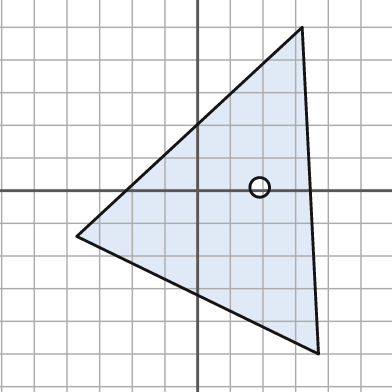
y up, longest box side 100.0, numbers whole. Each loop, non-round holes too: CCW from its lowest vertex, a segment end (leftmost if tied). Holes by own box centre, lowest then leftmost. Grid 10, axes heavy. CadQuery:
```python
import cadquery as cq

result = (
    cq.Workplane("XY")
    .moveTo(37.0, -50.0)
    .lineTo(32.0, 50.0)
    .lineTo(-37.0, -14.0)
    .close()
    .moveTo(19.0, 1.0)
    .circle(3.0)
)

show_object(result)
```